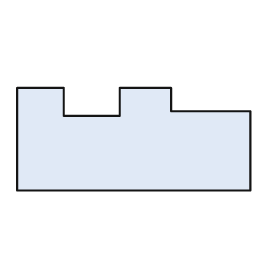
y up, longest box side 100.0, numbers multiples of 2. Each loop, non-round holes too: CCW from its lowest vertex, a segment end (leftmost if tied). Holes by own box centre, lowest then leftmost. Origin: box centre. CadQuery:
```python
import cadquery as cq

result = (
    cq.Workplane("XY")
    .moveTo(-50.0, -22.0)
    .lineTo(50.0, -22.0)
    .lineTo(50.0, 12.0)
    .lineTo(16.0, 12.0)
    .lineTo(16.0, 22.0)
    .lineTo(-6.0, 22.0)
    .lineTo(-6.0, 10.0)
    .lineTo(-30.0, 10.0)
    .lineTo(-30.0, 22.0)
    .lineTo(-50.0, 22.0)
    .close()
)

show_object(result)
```